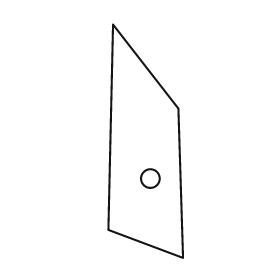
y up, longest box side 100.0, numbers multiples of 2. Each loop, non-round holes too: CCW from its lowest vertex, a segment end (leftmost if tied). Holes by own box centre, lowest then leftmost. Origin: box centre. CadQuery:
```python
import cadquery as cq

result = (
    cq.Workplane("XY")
    .moveTo(16.0, -50.0)
    .lineTo(14.0, 14.0)
    .lineTo(-14.0, 50.0)
    .lineTo(-16.0, -38.0)
    .close()
    .moveTo(2.0, -16.0)
    .circle(4.0)
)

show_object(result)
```